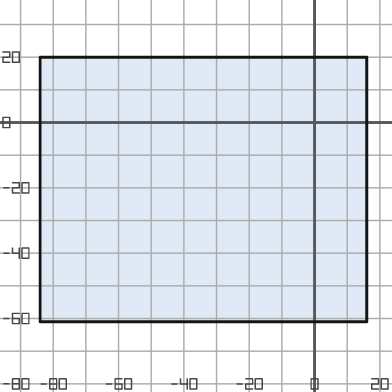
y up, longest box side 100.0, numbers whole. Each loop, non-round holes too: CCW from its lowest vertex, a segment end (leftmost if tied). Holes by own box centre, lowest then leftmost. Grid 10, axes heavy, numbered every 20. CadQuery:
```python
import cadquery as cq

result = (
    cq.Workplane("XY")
    .moveTo(-84.0, -61.0)
    .lineTo(16.0, -61.0)
    .lineTo(16.0, 20.0)
    .lineTo(-84.0, 20.0)
    .close()
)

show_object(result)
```